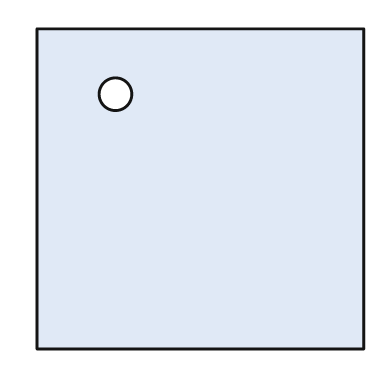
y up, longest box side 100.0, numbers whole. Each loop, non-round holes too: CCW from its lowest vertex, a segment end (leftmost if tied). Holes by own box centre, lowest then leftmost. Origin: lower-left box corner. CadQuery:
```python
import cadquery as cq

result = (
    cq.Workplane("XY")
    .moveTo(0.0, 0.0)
    .lineTo(100.0, 0.0)
    .lineTo(100.0, 98.0)
    .lineTo(0.0, 98.0)
    .close()
    .moveTo(24.0, 78.0)
    .circle(5.0)
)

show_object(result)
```